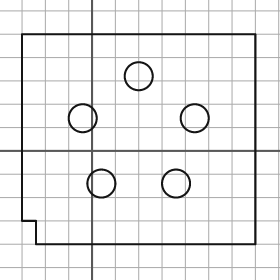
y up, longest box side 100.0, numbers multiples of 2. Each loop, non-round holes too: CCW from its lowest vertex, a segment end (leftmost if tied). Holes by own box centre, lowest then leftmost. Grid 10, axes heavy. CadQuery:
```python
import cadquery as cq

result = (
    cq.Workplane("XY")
    .moveTo(-24.0, -40.0)
    .lineTo(70.0, -40.0)
    .lineTo(70.0, 50.0)
    .lineTo(-30.0, 50.0)
    .lineTo(-30.0, -30.0)
    .lineTo(-24.0, -30.0)
    .close()
    .moveTo(4.0, -14.0)
    .circle(6.0)
    .moveTo(36.0, -14.0)
    .circle(6.0)
    .moveTo(-4.0, 14.0)
    .circle(6.0)
    .moveTo(44.0, 14.0)
    .circle(6.0)
    .moveTo(20.0, 32.0)
    .circle(6.0)
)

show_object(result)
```